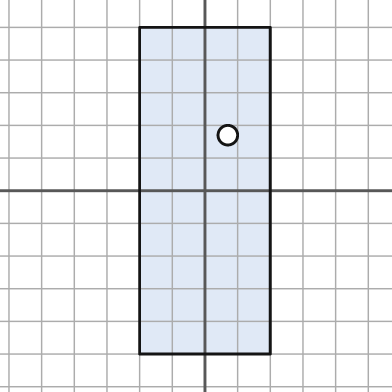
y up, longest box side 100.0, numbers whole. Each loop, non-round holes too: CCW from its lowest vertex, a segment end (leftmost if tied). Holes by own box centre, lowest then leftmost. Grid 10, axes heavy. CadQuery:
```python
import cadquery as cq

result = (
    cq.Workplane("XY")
    .moveTo(-20.0, -50.0)
    .lineTo(20.0, -50.0)
    .lineTo(20.0, 50.0)
    .lineTo(-20.0, 50.0)
    .close()
    .moveTo(7.0, 17.0)
    .circle(3.0)
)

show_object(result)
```